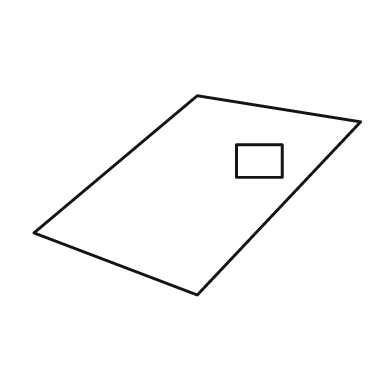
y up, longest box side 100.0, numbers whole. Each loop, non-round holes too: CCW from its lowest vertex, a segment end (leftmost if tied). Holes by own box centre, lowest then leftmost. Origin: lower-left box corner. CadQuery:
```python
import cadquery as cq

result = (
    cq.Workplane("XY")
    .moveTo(50.0, 0.0)
    .lineTo(100.0, 53.0)
    .lineTo(50.0, 61.0)
    .lineTo(0.0, 19.0)
    .close()
    .moveTo(62.0, 36.0)
    .lineTo(76.0, 36.0)
    .lineTo(76.0, 46.0)
    .lineTo(62.0, 46.0)
    .close()
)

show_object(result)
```